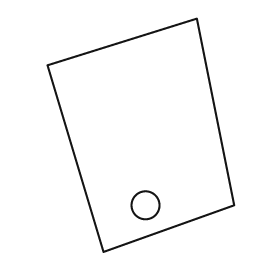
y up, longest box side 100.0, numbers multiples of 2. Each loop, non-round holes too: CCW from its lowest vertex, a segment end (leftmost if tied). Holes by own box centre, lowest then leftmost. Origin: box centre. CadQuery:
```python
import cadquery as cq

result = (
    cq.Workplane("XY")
    .moveTo(-16.0, -50.0)
    .lineTo(40.0, -30.0)
    .lineTo(24.0, 50.0)
    .lineTo(-40.0, 30.0)
    .close()
    .moveTo(2.0, -30.0)
    .circle(6.0)
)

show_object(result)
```